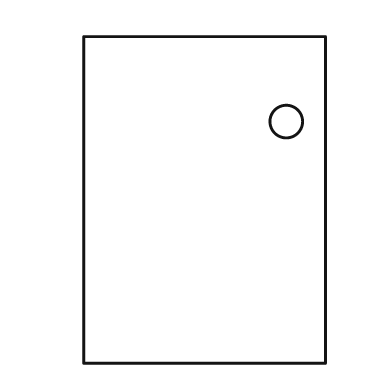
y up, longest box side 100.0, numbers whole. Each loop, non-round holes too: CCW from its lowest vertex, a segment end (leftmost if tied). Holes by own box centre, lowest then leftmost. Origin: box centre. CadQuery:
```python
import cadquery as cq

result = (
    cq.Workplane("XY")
    .moveTo(-37.0, -50.0)
    .lineTo(37.0, -50.0)
    .lineTo(37.0, 50.0)
    .lineTo(-37.0, 50.0)
    .close()
    .moveTo(25.0, 24.0)
    .circle(5.0)
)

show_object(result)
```